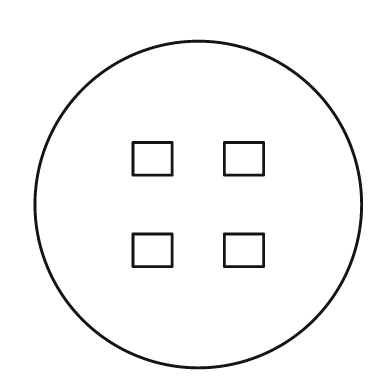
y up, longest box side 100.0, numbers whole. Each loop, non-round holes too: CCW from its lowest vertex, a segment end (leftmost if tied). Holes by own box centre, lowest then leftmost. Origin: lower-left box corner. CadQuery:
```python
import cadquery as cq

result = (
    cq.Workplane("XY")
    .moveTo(50.0, 50.0)
    .circle(50.0)
    .moveTo(30.0, 31.0)
    .lineTo(42.0, 31.0)
    .lineTo(42.0, 41.0)
    .lineTo(30.0, 41.0)
    .close()
    .moveTo(58.0, 31.0)
    .lineTo(70.0, 31.0)
    .lineTo(70.0, 41.0)
    .lineTo(58.0, 41.0)
    .close()
    .moveTo(30.0, 59.0)
    .lineTo(42.0, 59.0)
    .lineTo(42.0, 69.0)
    .lineTo(30.0, 69.0)
    .close()
    .moveTo(58.0, 59.0)
    .lineTo(70.0, 59.0)
    .lineTo(70.0, 69.0)
    .lineTo(58.0, 69.0)
    .close()
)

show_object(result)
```